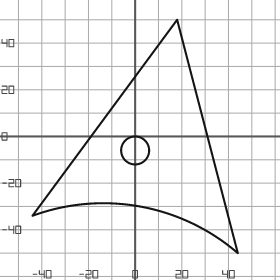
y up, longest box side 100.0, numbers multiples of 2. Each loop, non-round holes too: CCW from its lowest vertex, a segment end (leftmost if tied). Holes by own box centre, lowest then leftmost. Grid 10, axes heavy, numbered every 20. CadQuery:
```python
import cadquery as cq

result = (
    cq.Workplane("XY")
    .moveTo(44.0, -50.0)
    .lineTo(18.0, 50.0)
    .lineTo(-44.0, -34.0)
    .threePointArc((2.0, -30.0), (44.0, -50.0))
    .close()
    .moveTo(0.0, -6.0)
    .circle(6.0)
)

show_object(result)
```